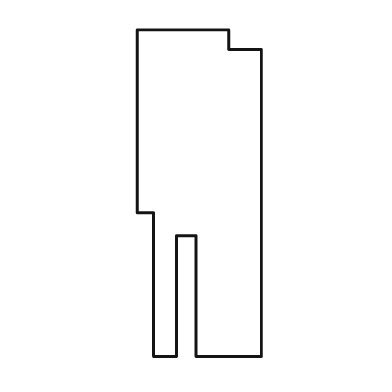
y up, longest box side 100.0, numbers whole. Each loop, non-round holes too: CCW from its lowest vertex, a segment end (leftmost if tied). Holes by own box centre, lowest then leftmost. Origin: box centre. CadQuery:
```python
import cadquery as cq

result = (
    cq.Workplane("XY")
    .moveTo(-14.0, -50.0)
    .lineTo(-7.0, -50.0)
    .lineTo(-7.0, -13.0)
    .lineTo(-1.0, -13.0)
    .lineTo(-1.0, -50.0)
    .lineTo(19.0, -50.0)
    .lineTo(19.0, 44.0)
    .lineTo(9.0, 44.0)
    .lineTo(9.0, 50.0)
    .lineTo(-19.0, 50.0)
    .lineTo(-19.0, -6.0)
    .lineTo(-14.0, -6.0)
    .close()
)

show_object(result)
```